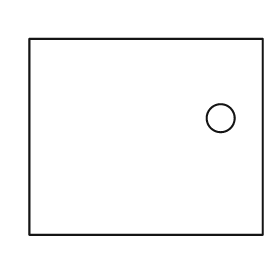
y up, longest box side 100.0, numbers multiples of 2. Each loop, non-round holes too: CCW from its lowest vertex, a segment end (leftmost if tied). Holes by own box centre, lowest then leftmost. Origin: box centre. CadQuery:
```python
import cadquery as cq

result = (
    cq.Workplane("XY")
    .moveTo(-50.0, -42.0)
    .lineTo(50.0, -42.0)
    .lineTo(50.0, 42.0)
    .lineTo(-50.0, 42.0)
    .close()
    .moveTo(32.0, 8.0)
    .circle(6.0)
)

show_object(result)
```